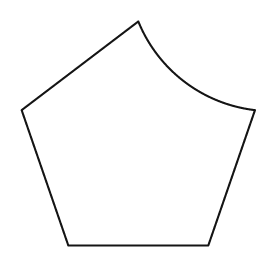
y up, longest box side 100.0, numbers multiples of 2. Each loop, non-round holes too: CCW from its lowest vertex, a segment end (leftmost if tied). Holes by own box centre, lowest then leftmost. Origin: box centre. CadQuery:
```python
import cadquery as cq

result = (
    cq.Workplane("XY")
    .moveTo(-30.0, -48.0)
    .lineTo(30.0, -48.0)
    .lineTo(50.0, 10.0)
    .threePointArc((20.0, 22.0), (0.0, 48.0))
    .lineTo(-50.0, 10.0)
    .close()
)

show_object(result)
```